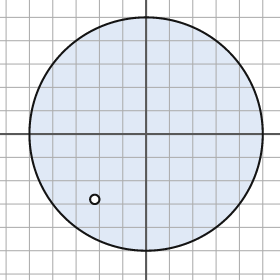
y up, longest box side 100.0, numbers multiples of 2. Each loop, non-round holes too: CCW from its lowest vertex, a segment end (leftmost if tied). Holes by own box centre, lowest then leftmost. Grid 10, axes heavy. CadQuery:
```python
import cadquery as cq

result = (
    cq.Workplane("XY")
    .moveTo(0.0, 0.0)
    .circle(50.0)
    .moveTo(-22.0, -28.0)
    .circle(2.0)
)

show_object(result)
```